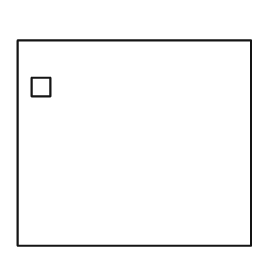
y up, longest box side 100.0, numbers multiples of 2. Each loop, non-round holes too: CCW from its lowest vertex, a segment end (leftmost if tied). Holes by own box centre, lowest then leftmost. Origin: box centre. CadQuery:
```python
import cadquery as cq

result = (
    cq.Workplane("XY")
    .moveTo(-50.0, -44.0)
    .lineTo(50.0, -44.0)
    .lineTo(50.0, 44.0)
    .lineTo(-50.0, 44.0)
    .close()
    .moveTo(-44.0, 20.0)
    .lineTo(-36.0, 20.0)
    .lineTo(-36.0, 28.0)
    .lineTo(-44.0, 28.0)
    .close()
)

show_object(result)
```